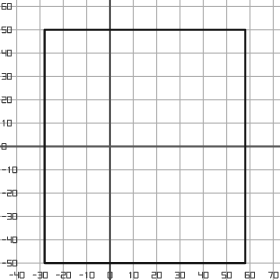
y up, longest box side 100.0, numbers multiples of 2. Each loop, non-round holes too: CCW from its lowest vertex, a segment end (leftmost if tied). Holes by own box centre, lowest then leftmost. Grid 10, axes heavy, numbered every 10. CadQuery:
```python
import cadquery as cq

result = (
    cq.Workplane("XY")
    .moveTo(-28.0, -50.0)
    .lineTo(58.0, -50.0)
    .lineTo(58.0, 50.0)
    .lineTo(-28.0, 50.0)
    .close()
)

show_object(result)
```